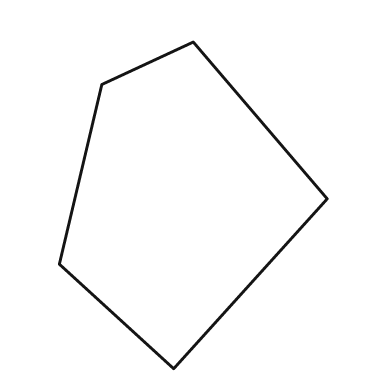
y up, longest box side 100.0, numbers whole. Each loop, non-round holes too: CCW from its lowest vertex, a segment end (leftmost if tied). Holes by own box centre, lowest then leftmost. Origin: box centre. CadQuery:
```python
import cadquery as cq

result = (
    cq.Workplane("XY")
    .moveTo(-6.0, -50.0)
    .lineTo(41.0, 2.0)
    .lineTo(0.0, 50.0)
    .lineTo(-28.0, 37.0)
    .lineTo(-41.0, -18.0)
    .close()
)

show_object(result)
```